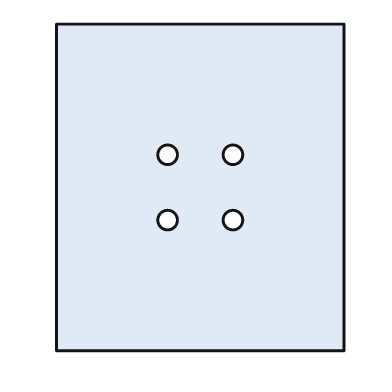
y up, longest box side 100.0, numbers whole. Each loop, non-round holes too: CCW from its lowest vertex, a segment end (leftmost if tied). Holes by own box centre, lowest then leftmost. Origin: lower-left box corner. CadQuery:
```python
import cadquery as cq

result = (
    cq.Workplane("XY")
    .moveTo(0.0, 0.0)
    .lineTo(88.0, 0.0)
    .lineTo(88.0, 100.0)
    .lineTo(0.0, 100.0)
    .close()
    .moveTo(34.0, 40.0)
    .circle(3.0)
    .moveTo(54.0, 40.0)
    .circle(3.0)
    .moveTo(34.0, 60.0)
    .circle(3.0)
    .moveTo(54.0, 60.0)
    .circle(3.0)
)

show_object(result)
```